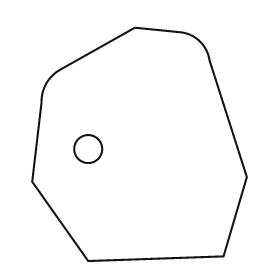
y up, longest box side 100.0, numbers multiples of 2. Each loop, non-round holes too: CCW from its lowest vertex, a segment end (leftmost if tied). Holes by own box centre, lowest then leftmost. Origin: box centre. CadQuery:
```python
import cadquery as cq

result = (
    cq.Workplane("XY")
    .moveTo(-22.0, -50.0)
    .lineTo(36.0, -48.0)
    .lineTo(46.0, -14.0)
    .lineTo(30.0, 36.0)
    .threePointArc((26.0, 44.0), (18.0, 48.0))
    .lineTo(-2.0, 50.0)
    .lineTo(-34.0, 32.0)
    .threePointArc((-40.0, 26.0), (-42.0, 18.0))
    .lineTo(-46.0, -16.0)
    .close()
    .moveTo(-22.0, -2.0)
    .circle(6.0)
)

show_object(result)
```